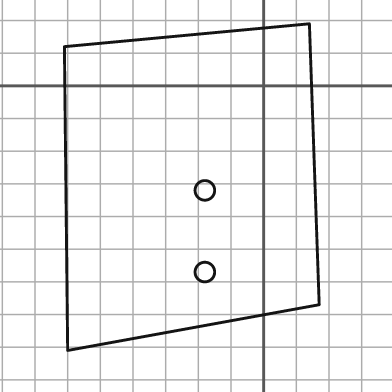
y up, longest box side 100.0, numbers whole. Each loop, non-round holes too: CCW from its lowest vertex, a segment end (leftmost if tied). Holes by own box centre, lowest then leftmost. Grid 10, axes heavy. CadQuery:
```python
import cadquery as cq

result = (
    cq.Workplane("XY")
    .moveTo(-60.0, -81.0)
    .lineTo(17.0, -67.0)
    .lineTo(14.0, 19.0)
    .lineTo(-61.0, 12.0)
    .close()
    .moveTo(-18.0, -57.0)
    .circle(3.0)
    .moveTo(-18.0, -32.0)
    .circle(3.0)
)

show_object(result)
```